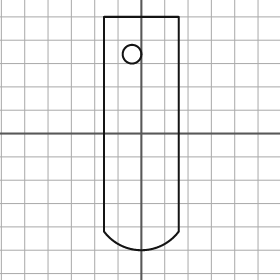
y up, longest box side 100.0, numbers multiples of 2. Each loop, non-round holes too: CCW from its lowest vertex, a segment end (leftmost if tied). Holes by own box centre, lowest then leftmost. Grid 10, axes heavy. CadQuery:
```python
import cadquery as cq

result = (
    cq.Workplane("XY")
    .moveTo(-16.0, -42.0)
    .threePointArc((0.0, -50.0), (16.0, -42.0))
    .lineTo(16.0, 50.0)
    .lineTo(-16.0, 50.0)
    .close()
    .moveTo(-4.0, 34.0)
    .circle(4.0)
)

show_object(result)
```